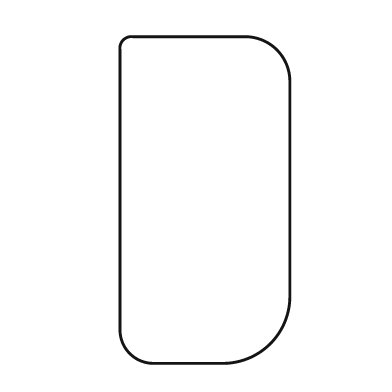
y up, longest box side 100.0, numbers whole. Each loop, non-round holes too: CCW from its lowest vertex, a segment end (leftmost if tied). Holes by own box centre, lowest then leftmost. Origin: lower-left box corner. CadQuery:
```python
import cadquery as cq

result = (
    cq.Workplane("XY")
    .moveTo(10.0, 0.0)
    .lineTo(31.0, 0.0)
    .threePointArc((46.0, 6.0), (52.0, 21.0))
    .lineTo(52.0, 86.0)
    .threePointArc((48.0, 96.0), (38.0, 100.0))
    .lineTo(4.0, 100.0)
    .threePointArc((1.0, 99.0), (0.0, 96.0))
    .lineTo(0.0, 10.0)
    .threePointArc((3.0, 3.0), (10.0, 0.0))
    .close()
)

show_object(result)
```